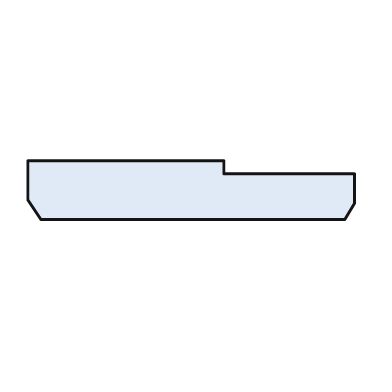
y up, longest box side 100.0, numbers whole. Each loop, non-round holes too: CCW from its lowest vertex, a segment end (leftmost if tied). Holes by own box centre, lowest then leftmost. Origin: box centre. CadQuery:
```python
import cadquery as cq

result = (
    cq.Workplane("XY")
    .moveTo(-46.0, -9.0)
    .lineTo(47.0, -9.0)
    .lineTo(50.0, -4.0)
    .lineTo(50.0, 5.0)
    .lineTo(10.0, 5.0)
    .lineTo(10.0, 9.0)
    .lineTo(-50.0, 9.0)
    .lineTo(-50.0, -3.0)
    .close()
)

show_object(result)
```